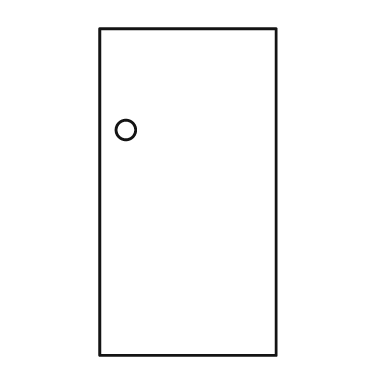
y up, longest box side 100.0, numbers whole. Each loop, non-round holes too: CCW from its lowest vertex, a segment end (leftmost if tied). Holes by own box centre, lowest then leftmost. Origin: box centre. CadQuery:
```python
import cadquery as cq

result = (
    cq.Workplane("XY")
    .moveTo(-27.0, -50.0)
    .lineTo(27.0, -50.0)
    .lineTo(27.0, 50.0)
    .lineTo(-27.0, 50.0)
    .close()
    .moveTo(-19.0, 19.0)
    .circle(3.0)
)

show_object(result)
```